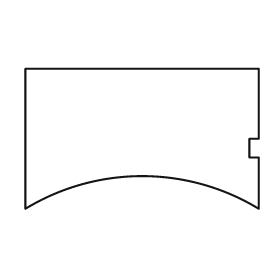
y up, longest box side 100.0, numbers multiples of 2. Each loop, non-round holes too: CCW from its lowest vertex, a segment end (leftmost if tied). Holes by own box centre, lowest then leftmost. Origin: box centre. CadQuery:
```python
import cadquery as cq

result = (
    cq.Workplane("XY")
    .moveTo(-50.0, -30.0)
    .threePointArc((0.0, -16.0), (50.0, -30.0))
    .lineTo(50.0, -8.0)
    .lineTo(46.0, -8.0)
    .lineTo(46.0, 0.0)
    .lineTo(50.0, 0.0)
    .lineTo(50.0, 30.0)
    .lineTo(-50.0, 30.0)
    .close()
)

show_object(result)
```